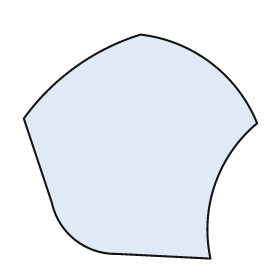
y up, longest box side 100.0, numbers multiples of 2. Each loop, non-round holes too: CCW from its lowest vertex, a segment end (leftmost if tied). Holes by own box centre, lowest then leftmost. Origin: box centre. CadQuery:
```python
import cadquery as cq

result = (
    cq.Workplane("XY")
    .moveTo(30.0, -48.0)
    .threePointArc((32.0, -16.0), (50.0, 10.0))
    .threePointArc((30.0, 36.0), (0.0, 48.0))
    .threePointArc((-28.0, 34.0), (-50.0, 12.0))
    .lineTo(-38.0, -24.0)
    .threePointArc((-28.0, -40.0), (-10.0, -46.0))
    .close()
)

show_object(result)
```